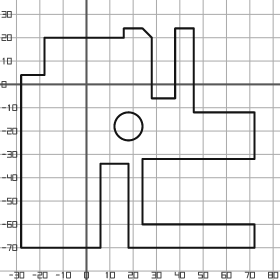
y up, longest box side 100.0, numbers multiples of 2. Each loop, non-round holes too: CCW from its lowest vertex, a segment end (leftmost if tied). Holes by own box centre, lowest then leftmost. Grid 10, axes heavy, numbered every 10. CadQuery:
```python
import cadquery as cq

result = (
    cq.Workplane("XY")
    .moveTo(-28.0, -70.0)
    .lineTo(6.0, -70.0)
    .lineTo(6.0, -34.0)
    .lineTo(18.0, -34.0)
    .lineTo(18.0, -70.0)
    .lineTo(72.0, -70.0)
    .lineTo(72.0, -60.0)
    .lineTo(24.0, -60.0)
    .lineTo(24.0, -32.0)
    .lineTo(72.0, -32.0)
    .lineTo(72.0, -12.0)
    .lineTo(46.0, -12.0)
    .lineTo(46.0, 24.0)
    .lineTo(38.0, 24.0)
    .lineTo(38.0, -6.0)
    .lineTo(28.0, -6.0)
    .lineTo(28.0, 20.0)
    .lineTo(24.0, 24.0)
    .lineTo(16.0, 24.0)
    .lineTo(16.0, 20.0)
    .lineTo(-18.0, 20.0)
    .lineTo(-18.0, 4.0)
    .lineTo(-28.0, 4.0)
    .close()
    .moveTo(18.0, -18.0)
    .circle(6.0)
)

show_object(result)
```